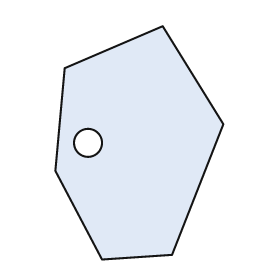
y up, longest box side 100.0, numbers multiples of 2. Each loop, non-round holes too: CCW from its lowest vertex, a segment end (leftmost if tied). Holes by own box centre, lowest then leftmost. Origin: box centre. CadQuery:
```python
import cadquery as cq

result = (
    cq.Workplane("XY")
    .moveTo(-16.0, -50.0)
    .lineTo(14.0, -48.0)
    .lineTo(36.0, 8.0)
    .lineTo(10.0, 50.0)
    .lineTo(-32.0, 32.0)
    .lineTo(-36.0, -12.0)
    .close()
    .moveTo(-22.0, 0.0)
    .circle(6.0)
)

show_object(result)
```